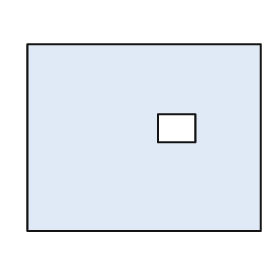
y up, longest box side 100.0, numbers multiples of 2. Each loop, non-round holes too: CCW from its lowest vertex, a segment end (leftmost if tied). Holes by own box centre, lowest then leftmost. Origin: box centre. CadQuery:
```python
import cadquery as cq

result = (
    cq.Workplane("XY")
    .moveTo(-50.0, -40.0)
    .lineTo(50.0, -40.0)
    .lineTo(50.0, 40.0)
    .lineTo(-50.0, 40.0)
    .close()
    .moveTo(6.0, -2.0)
    .lineTo(22.0, -2.0)
    .lineTo(22.0, 10.0)
    .lineTo(6.0, 10.0)
    .close()
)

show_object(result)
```